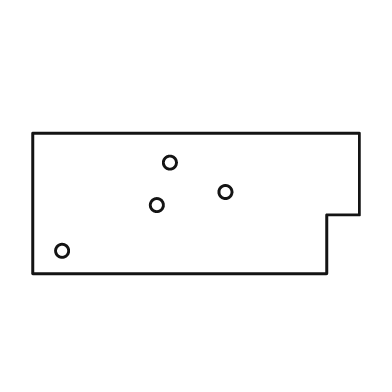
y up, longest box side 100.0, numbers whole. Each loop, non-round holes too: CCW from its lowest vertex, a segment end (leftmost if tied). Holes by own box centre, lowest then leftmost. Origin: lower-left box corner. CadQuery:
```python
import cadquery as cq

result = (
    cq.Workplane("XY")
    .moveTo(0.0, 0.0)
    .lineTo(90.0, 0.0)
    .lineTo(90.0, 18.0)
    .lineTo(100.0, 18.0)
    .lineTo(100.0, 43.0)
    .lineTo(0.0, 43.0)
    .close()
    .moveTo(9.0, 7.0)
    .circle(2.0)
    .moveTo(38.0, 21.0)
    .circle(2.0)
    .moveTo(59.0, 25.0)
    .circle(2.0)
    .moveTo(42.0, 34.0)
    .circle(2.0)
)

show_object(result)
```